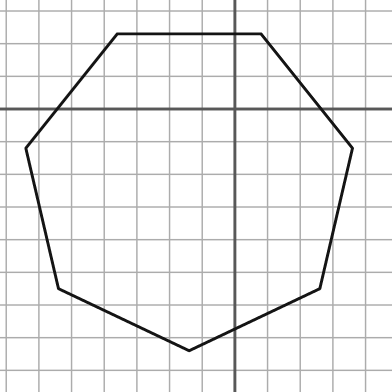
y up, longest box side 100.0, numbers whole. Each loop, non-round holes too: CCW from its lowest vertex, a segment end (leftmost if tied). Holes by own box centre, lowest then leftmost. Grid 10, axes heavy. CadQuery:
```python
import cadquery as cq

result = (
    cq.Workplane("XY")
    .moveTo(-14.0, -74.0)
    .lineTo(26.0, -55.0)
    .lineTo(36.0, -12.0)
    .lineTo(8.0, 23.0)
    .lineTo(-36.0, 23.0)
    .lineTo(-64.0, -12.0)
    .lineTo(-54.0, -55.0)
    .close()
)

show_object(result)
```